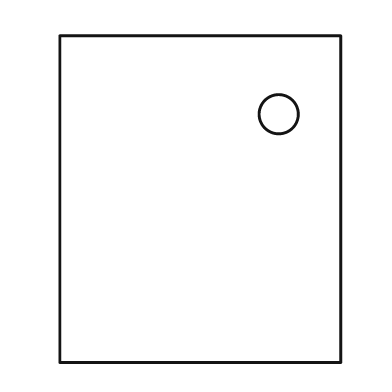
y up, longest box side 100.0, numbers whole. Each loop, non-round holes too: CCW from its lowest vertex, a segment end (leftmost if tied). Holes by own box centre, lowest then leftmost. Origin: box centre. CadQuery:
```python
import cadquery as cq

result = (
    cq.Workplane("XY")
    .moveTo(-43.0, -50.0)
    .lineTo(43.0, -50.0)
    .lineTo(43.0, 50.0)
    .lineTo(-43.0, 50.0)
    .close()
    .moveTo(24.0, 26.0)
    .circle(6.0)
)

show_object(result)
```